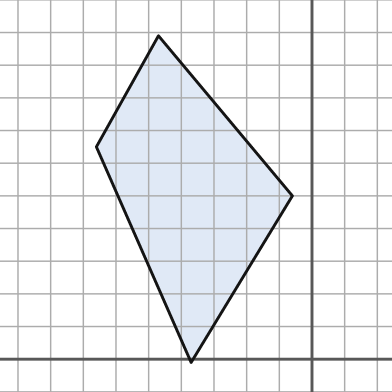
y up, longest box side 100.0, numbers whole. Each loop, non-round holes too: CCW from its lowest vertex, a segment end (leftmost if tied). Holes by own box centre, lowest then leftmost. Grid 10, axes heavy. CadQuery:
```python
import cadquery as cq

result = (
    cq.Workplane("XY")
    .moveTo(-37.0, -1.0)
    .lineTo(-6.0, 50.0)
    .lineTo(-47.0, 99.0)
    .lineTo(-66.0, 65.0)
    .close()
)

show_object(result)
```